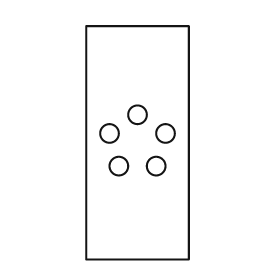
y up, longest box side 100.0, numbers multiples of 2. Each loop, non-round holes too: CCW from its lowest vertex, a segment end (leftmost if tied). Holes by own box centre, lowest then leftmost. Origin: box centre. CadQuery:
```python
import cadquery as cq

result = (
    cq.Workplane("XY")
    .moveTo(-22.0, -50.0)
    .lineTo(22.0, -50.0)
    .lineTo(22.0, 50.0)
    .lineTo(-22.0, 50.0)
    .close()
    .moveTo(-8.0, -10.0)
    .circle(4.0)
    .moveTo(8.0, -10.0)
    .circle(4.0)
    .moveTo(-12.0, 4.0)
    .circle(4.0)
    .moveTo(12.0, 4.0)
    .circle(4.0)
    .moveTo(0.0, 12.0)
    .circle(4.0)
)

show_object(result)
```